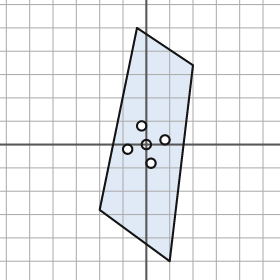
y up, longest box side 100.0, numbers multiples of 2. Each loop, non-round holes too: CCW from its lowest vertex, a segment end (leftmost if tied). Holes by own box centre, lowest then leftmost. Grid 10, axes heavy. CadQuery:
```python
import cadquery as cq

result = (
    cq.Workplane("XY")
    .moveTo(10.0, -50.0)
    .lineTo(20.0, 34.0)
    .lineTo(-4.0, 50.0)
    .lineTo(-20.0, -28.0)
    .close()
    .moveTo(2.0, -8.0)
    .circle(2.0)
    .moveTo(-8.0, -2.0)
    .circle(2.0)
    .moveTo(0.0, 0.0)
    .circle(2.0)
    .moveTo(8.0, 2.0)
    .circle(2.0)
    .moveTo(-2.0, 8.0)
    .circle(2.0)
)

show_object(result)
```